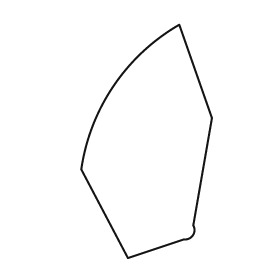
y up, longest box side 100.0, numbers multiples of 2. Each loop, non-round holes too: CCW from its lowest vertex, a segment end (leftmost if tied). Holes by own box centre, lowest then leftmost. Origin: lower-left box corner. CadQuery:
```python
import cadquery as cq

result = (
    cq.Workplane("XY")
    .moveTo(20.0, 0.0)
    .lineTo(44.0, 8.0)
    .threePointArc((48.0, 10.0), (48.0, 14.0))
    .lineTo(56.0, 60.0)
    .lineTo(42.0, 100.0)
    .threePointArc((14.0, 74.0), (0.0, 38.0))
    .close()
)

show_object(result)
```